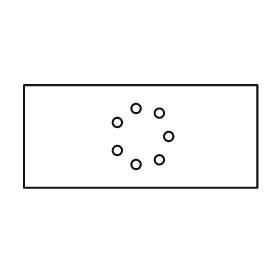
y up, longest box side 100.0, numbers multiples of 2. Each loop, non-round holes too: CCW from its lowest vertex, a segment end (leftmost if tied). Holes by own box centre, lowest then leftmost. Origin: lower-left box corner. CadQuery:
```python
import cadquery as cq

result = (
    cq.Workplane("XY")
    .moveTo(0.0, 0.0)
    .lineTo(100.0, 0.0)
    .lineTo(100.0, 44.0)
    .lineTo(0.0, 44.0)
    .close()
    .moveTo(48.0, 10.0)
    .circle(2.0)
    .moveTo(58.0, 12.0)
    .circle(2.0)
    .moveTo(40.0, 16.0)
    .circle(2.0)
    .moveTo(62.0, 22.0)
    .circle(2.0)
    .moveTo(40.0, 28.0)
    .circle(2.0)
    .moveTo(58.0, 32.0)
    .circle(2.0)
    .moveTo(48.0, 34.0)
    .circle(2.0)
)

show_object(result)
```